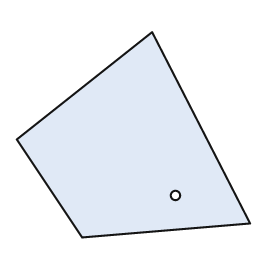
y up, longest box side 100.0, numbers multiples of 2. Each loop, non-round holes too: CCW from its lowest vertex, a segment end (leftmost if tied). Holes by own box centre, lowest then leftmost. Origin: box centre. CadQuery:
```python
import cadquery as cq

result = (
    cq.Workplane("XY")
    .moveTo(-22.0, -44.0)
    .lineTo(50.0, -38.0)
    .lineTo(8.0, 44.0)
    .lineTo(-50.0, -2.0)
    .close()
    .moveTo(18.0, -26.0)
    .circle(2.0)
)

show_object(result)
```